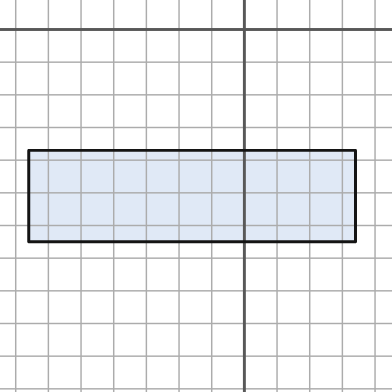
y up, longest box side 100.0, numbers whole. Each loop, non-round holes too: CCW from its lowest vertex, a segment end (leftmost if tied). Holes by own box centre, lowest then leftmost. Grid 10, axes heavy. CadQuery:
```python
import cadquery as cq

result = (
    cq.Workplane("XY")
    .moveTo(-66.0, -65.0)
    .lineTo(34.0, -65.0)
    .lineTo(34.0, -37.0)
    .lineTo(-66.0, -37.0)
    .close()
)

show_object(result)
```